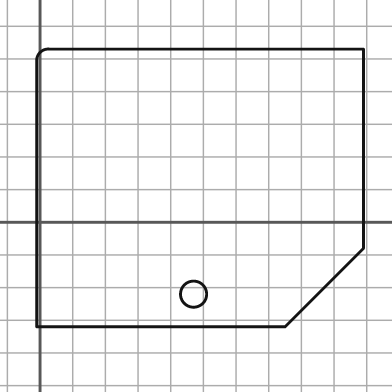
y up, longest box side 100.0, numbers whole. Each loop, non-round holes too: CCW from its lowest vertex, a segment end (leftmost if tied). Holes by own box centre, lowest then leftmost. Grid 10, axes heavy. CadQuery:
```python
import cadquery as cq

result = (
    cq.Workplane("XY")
    .moveTo(-1.0, -32.0)
    .lineTo(75.0, -32.0)
    .lineTo(99.0, -8.0)
    .lineTo(99.0, 53.0)
    .lineTo(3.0, 53.0)
    .threePointArc((0.0, 52.0), (-1.0, 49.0))
    .close()
    .moveTo(47.0, -22.0)
    .circle(4.0)
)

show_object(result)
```